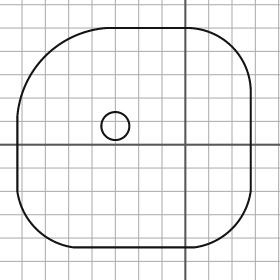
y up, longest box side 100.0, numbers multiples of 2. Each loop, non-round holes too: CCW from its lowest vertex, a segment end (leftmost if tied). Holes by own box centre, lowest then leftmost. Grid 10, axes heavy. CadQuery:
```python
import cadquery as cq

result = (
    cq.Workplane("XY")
    .moveTo(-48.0, -44.0)
    .lineTo(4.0, -44.0)
    .threePointArc((20.0, -36.0), (28.0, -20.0))
    .lineTo(28.0, 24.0)
    .threePointArc((20.0, 42.0), (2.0, 50.0))
    .lineTo(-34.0, 50.0)
    .threePointArc((-60.0, 38.0), (-72.0, 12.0))
    .lineTo(-72.0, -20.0)
    .threePointArc((-64.0, -36.0), (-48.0, -44.0))
    .close()
    .moveTo(-30.0, 8.0)
    .circle(6.0)
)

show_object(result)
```